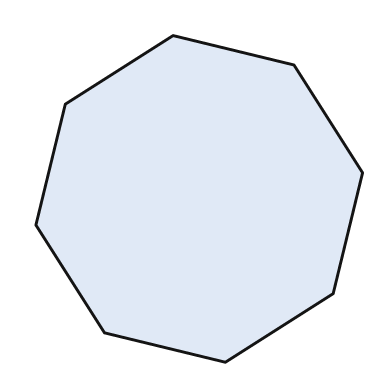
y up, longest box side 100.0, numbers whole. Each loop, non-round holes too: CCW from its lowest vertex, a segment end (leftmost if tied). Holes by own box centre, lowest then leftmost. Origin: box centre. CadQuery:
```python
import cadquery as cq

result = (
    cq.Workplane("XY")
    .moveTo(8.0, -50.0)
    .lineTo(41.0, -29.0)
    .lineTo(50.0, 8.0)
    .lineTo(29.0, 41.0)
    .lineTo(-8.0, 50.0)
    .lineTo(-41.0, 29.0)
    .lineTo(-50.0, -8.0)
    .lineTo(-29.0, -41.0)
    .close()
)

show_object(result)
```